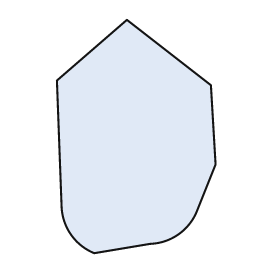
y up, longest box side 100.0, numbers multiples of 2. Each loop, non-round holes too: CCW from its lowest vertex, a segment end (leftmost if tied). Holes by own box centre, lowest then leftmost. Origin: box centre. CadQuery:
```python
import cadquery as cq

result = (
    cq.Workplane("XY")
    .moveTo(-18.0, -50.0)
    .lineTo(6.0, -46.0)
    .threePointArc((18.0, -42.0), (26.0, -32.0))
    .lineTo(34.0, -12.0)
    .lineTo(32.0, 22.0)
    .lineTo(-4.0, 50.0)
    .lineTo(-34.0, 24.0)
    .lineTo(-32.0, -30.0)
    .threePointArc((-28.0, -42.0), (-18.0, -50.0))
    .close()
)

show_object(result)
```